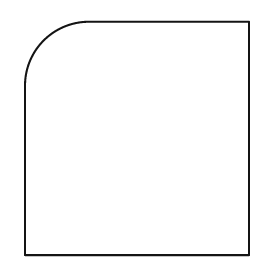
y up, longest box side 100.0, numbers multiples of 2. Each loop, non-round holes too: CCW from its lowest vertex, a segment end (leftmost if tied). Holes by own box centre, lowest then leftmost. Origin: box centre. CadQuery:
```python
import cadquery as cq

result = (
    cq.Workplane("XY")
    .moveTo(-48.0, -50.0)
    .lineTo(48.0, -50.0)
    .lineTo(48.0, 50.0)
    .lineTo(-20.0, 50.0)
    .threePointArc((-40.0, 42.0), (-48.0, 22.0))
    .close()
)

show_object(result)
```